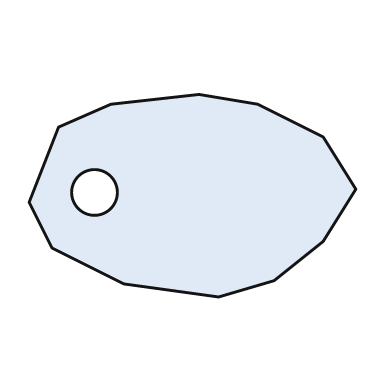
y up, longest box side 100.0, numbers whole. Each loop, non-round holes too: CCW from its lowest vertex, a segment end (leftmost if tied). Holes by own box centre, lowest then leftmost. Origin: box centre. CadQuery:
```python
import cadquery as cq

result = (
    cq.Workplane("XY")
    .moveTo(8.0, -31.0)
    .lineTo(25.0, -26.0)
    .lineTo(40.0, -14.0)
    .lineTo(50.0, 2.0)
    .lineTo(40.0, 18.0)
    .lineTo(20.0, 28.0)
    .lineTo(2.0, 31.0)
    .lineTo(-25.0, 28.0)
    .lineTo(-41.0, 21.0)
    .lineTo(-50.0, -2.0)
    .lineTo(-43.0, -16.0)
    .lineTo(-21.0, -27.0)
    .close()
    .moveTo(-30.0, 1.0)
    .circle(7.0)
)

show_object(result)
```